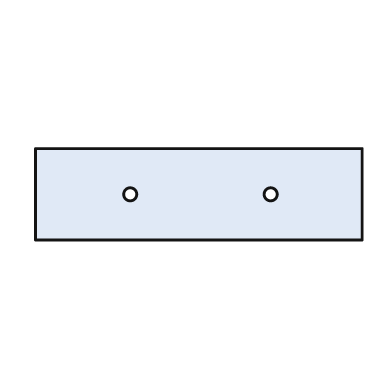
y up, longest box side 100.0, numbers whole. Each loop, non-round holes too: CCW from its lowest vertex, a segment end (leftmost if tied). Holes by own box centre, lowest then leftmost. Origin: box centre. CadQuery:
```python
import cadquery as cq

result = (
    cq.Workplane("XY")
    .moveTo(-50.0, -14.0)
    .lineTo(50.0, -14.0)
    .lineTo(50.0, 14.0)
    .lineTo(-50.0, 14.0)
    .close()
    .moveTo(-21.0, 0.0)
    .circle(2.0)
    .moveTo(22.0, 0.0)
    .circle(2.0)
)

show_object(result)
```